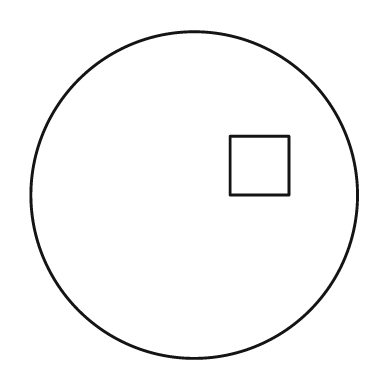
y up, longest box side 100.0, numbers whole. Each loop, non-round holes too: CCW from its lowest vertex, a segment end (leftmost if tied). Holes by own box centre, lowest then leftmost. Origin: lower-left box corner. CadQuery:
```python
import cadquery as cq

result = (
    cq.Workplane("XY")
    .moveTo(50.0, 50.0)
    .circle(50.0)
    .moveTo(61.0, 50.0)
    .lineTo(79.0, 50.0)
    .lineTo(79.0, 68.0)
    .lineTo(61.0, 68.0)
    .close()
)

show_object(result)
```